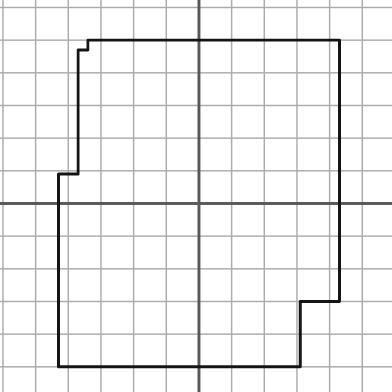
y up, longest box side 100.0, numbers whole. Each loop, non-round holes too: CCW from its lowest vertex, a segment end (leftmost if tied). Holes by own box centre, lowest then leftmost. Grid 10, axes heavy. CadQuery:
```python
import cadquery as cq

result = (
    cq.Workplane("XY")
    .moveTo(-43.0, -50.0)
    .lineTo(31.0, -50.0)
    .lineTo(31.0, -30.0)
    .lineTo(43.0, -30.0)
    .lineTo(43.0, 50.0)
    .lineTo(-34.0, 50.0)
    .lineTo(-34.0, 47.0)
    .lineTo(-37.0, 47.0)
    .lineTo(-37.0, 9.0)
    .lineTo(-43.0, 9.0)
    .close()
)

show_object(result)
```